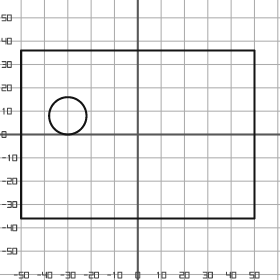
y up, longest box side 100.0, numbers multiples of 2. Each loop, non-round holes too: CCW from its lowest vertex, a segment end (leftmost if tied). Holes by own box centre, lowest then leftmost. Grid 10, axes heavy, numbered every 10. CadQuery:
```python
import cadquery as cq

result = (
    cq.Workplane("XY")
    .moveTo(-50.0, -36.0)
    .lineTo(50.0, -36.0)
    .lineTo(50.0, 36.0)
    .lineTo(-50.0, 36.0)
    .close()
    .moveTo(-30.0, 8.0)
    .circle(8.0)
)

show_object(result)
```